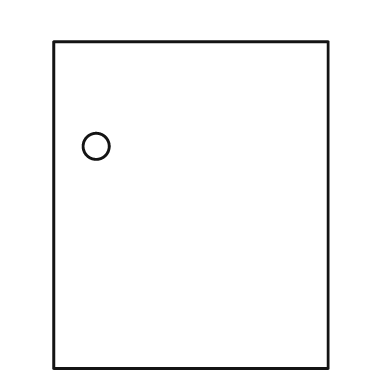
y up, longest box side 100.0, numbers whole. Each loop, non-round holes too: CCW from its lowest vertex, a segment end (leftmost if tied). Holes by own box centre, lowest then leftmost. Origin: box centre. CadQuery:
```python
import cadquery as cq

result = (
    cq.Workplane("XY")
    .moveTo(-42.0, -50.0)
    .lineTo(42.0, -50.0)
    .lineTo(42.0, 50.0)
    .lineTo(-42.0, 50.0)
    .close()
    .moveTo(-29.0, 18.0)
    .circle(4.0)
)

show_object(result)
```